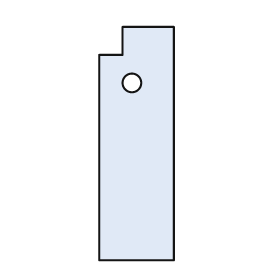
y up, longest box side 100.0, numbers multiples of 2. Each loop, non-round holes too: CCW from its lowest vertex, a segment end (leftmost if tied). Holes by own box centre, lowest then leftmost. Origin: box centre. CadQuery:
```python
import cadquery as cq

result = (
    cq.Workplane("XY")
    .moveTo(-16.0, -50.0)
    .lineTo(16.0, -50.0)
    .lineTo(16.0, 50.0)
    .lineTo(-6.0, 50.0)
    .lineTo(-6.0, 38.0)
    .lineTo(-16.0, 38.0)
    .close()
    .moveTo(-2.0, 26.0)
    .circle(4.0)
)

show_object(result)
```